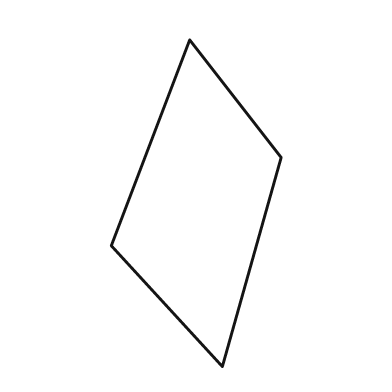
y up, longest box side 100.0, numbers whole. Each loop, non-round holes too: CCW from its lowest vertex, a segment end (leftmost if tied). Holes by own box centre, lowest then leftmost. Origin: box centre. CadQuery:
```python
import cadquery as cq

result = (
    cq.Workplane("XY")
    .moveTo(8.0, -50.0)
    .lineTo(26.0, 14.0)
    .lineTo(-2.0, 50.0)
    .lineTo(-26.0, -13.0)
    .close()
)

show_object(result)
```